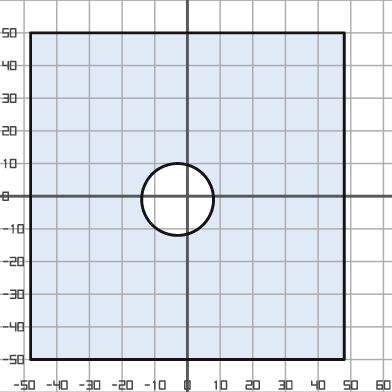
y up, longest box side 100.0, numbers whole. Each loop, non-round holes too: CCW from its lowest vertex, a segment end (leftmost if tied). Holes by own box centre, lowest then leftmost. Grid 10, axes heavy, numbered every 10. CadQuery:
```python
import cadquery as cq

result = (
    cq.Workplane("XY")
    .moveTo(-48.0, -50.0)
    .lineTo(48.0, -50.0)
    .lineTo(48.0, 50.0)
    .lineTo(-48.0, 50.0)
    .close()
    .moveTo(-3.0, -1.0)
    .circle(11.0)
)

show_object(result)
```